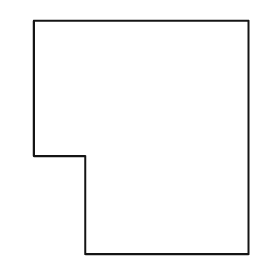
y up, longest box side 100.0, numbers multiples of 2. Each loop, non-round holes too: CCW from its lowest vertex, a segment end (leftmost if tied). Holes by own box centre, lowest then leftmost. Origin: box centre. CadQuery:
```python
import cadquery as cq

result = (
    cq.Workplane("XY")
    .moveTo(-24.0, -50.0)
    .lineTo(46.0, -50.0)
    .lineTo(46.0, 50.0)
    .lineTo(-46.0, 50.0)
    .lineTo(-46.0, -8.0)
    .lineTo(-24.0, -8.0)
    .close()
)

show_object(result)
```